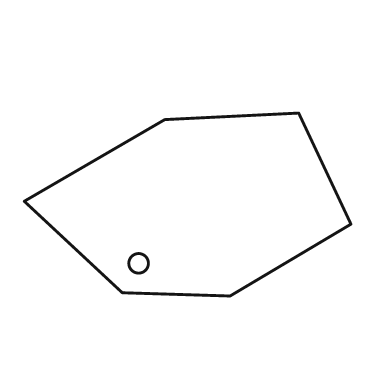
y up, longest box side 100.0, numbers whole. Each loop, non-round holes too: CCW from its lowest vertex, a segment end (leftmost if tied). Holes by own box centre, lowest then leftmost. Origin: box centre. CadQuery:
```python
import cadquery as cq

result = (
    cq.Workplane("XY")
    .moveTo(13.0, -28.0)
    .lineTo(50.0, -6.0)
    .lineTo(34.0, 28.0)
    .lineTo(-7.0, 26.0)
    .lineTo(-50.0, 1.0)
    .lineTo(-20.0, -27.0)
    .close()
    .moveTo(-15.0, -18.0)
    .circle(3.0)
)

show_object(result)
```